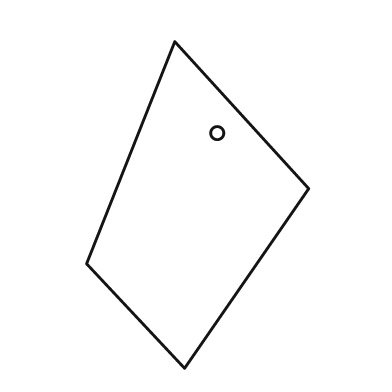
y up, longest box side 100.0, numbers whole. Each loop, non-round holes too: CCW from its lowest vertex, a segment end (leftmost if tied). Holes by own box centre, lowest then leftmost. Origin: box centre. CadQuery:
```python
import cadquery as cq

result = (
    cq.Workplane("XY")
    .moveTo(-4.0, -50.0)
    .lineTo(34.0, 5.0)
    .lineTo(-7.0, 50.0)
    .lineTo(-34.0, -18.0)
    .close()
    .moveTo(6.0, 22.0)
    .circle(2.0)
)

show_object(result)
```